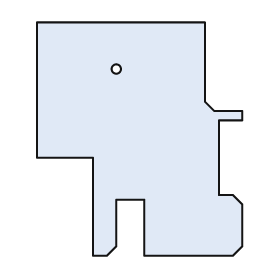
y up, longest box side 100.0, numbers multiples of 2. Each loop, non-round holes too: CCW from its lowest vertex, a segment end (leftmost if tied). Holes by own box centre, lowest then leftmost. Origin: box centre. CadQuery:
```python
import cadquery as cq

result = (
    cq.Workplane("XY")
    .moveTo(-20.0, -50.0)
    .lineTo(-14.0, -50.0)
    .lineTo(-10.0, -46.0)
    .lineTo(-10.0, -26.0)
    .lineTo(2.0, -26.0)
    .lineTo(2.0, -50.0)
    .lineTo(40.0, -50.0)
    .lineTo(44.0, -46.0)
    .lineTo(44.0, -28.0)
    .lineTo(40.0, -24.0)
    .lineTo(34.0, -24.0)
    .lineTo(34.0, 8.0)
    .lineTo(44.0, 8.0)
    .lineTo(44.0, 12.0)
    .lineTo(32.0, 12.0)
    .lineTo(28.0, 16.0)
    .lineTo(28.0, 50.0)
    .lineTo(-44.0, 50.0)
    .lineTo(-44.0, -8.0)
    .lineTo(-20.0, -8.0)
    .close()
    .moveTo(-10.0, 30.0)
    .circle(2.0)
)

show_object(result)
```